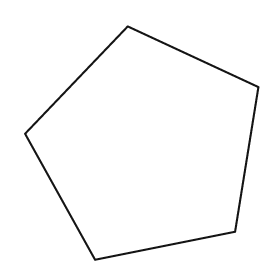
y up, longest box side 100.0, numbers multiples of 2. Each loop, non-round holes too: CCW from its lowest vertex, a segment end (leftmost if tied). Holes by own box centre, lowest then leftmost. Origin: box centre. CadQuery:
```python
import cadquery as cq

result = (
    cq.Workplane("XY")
    .moveTo(-20.0, -50.0)
    .lineTo(40.0, -38.0)
    .lineTo(50.0, 24.0)
    .lineTo(-6.0, 50.0)
    .lineTo(-50.0, 4.0)
    .close()
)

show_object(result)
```